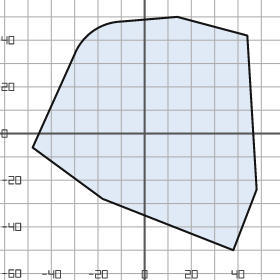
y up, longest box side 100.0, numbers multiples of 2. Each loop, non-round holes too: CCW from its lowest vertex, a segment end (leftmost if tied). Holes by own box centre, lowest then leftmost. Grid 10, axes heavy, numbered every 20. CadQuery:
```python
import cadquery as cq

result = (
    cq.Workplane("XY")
    .moveTo(38.0, -50.0)
    .lineTo(48.0, -24.0)
    .lineTo(44.0, 42.0)
    .lineTo(14.0, 50.0)
    .lineTo(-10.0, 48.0)
    .threePointArc((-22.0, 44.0), (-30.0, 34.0))
    .lineTo(-48.0, -6.0)
    .lineTo(-18.0, -28.0)
    .close()
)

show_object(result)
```